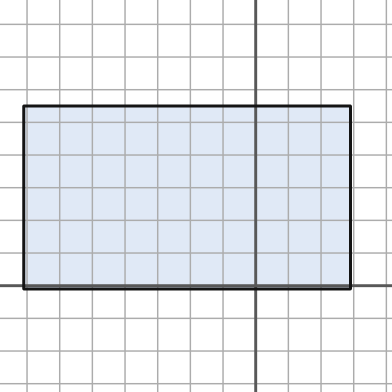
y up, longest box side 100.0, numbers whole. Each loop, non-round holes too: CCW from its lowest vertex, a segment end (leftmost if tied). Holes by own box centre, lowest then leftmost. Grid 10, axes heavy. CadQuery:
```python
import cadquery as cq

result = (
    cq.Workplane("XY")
    .moveTo(-71.0, -1.0)
    .lineTo(29.0, -1.0)
    .lineTo(29.0, 55.0)
    .lineTo(-71.0, 55.0)
    .close()
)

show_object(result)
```